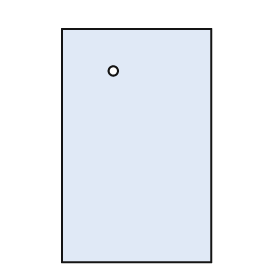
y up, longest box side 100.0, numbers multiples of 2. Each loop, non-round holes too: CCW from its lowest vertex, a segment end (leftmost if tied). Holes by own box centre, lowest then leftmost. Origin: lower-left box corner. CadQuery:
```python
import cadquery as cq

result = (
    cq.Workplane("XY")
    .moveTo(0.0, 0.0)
    .lineTo(64.0, 0.0)
    .lineTo(64.0, 100.0)
    .lineTo(0.0, 100.0)
    .close()
    .moveTo(22.0, 82.0)
    .circle(2.0)
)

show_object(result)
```